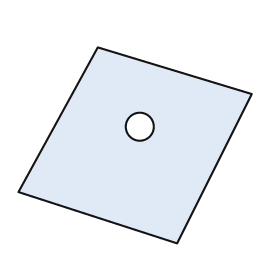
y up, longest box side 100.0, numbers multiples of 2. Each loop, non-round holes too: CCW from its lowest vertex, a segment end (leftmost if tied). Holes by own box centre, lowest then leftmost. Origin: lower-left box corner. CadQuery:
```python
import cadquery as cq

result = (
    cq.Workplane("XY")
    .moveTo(68.0, 0.0)
    .lineTo(100.0, 64.0)
    .lineTo(34.0, 84.0)
    .lineTo(0.0, 22.0)
    .close()
    .moveTo(52.0, 50.0)
    .circle(6.0)
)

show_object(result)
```